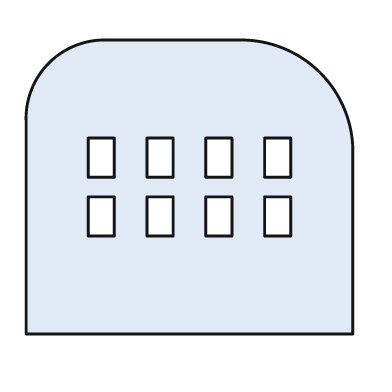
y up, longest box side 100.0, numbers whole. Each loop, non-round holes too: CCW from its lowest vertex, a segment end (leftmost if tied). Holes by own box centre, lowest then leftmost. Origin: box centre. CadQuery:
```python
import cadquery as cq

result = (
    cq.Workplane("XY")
    .moveTo(-50.0, -45.0)
    .lineTo(50.0, -45.0)
    .lineTo(50.0, 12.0)
    .threePointArc((40.0, 35.0), (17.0, 45.0))
    .lineTo(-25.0, 45.0)
    .threePointArc((-43.0, 38.0), (-50.0, 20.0))
    .close()
    .moveTo(-31.0, -15.0)
    .lineTo(-23.0, -15.0)
    .lineTo(-23.0, -3.0)
    .lineTo(-31.0, -3.0)
    .close()
    .moveTo(-13.0, -15.0)
    .lineTo(-5.0, -15.0)
    .lineTo(-5.0, -3.0)
    .lineTo(-13.0, -3.0)
    .close()
    .moveTo(5.0, -15.0)
    .lineTo(13.0, -15.0)
    .lineTo(13.0, -3.0)
    .lineTo(5.0, -3.0)
    .close()
    .moveTo(23.0, -15.0)
    .lineTo(31.0, -15.0)
    .lineTo(31.0, -3.0)
    .lineTo(23.0, -3.0)
    .close()
    .moveTo(-31.0, 3.0)
    .lineTo(-23.0, 3.0)
    .lineTo(-23.0, 15.0)
    .lineTo(-31.0, 15.0)
    .close()
    .moveTo(-13.0, 3.0)
    .lineTo(-5.0, 3.0)
    .lineTo(-5.0, 15.0)
    .lineTo(-13.0, 15.0)
    .close()
    .moveTo(5.0, 3.0)
    .lineTo(13.0, 3.0)
    .lineTo(13.0, 15.0)
    .lineTo(5.0, 15.0)
    .close()
    .moveTo(23.0, 3.0)
    .lineTo(31.0, 3.0)
    .lineTo(31.0, 15.0)
    .lineTo(23.0, 15.0)
    .close()
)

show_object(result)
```